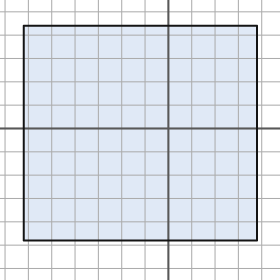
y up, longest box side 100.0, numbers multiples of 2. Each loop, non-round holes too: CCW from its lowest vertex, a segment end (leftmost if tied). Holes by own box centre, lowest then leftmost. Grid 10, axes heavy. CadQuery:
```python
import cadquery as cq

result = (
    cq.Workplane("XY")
    .moveTo(-62.0, -48.0)
    .lineTo(38.0, -48.0)
    .lineTo(38.0, 44.0)
    .lineTo(-62.0, 44.0)
    .close()
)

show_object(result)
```